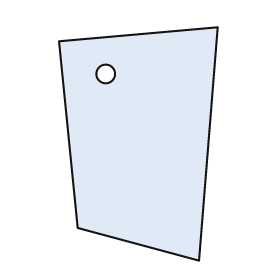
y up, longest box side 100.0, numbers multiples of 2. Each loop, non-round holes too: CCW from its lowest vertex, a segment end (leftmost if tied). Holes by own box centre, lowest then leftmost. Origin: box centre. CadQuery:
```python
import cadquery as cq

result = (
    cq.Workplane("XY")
    .moveTo(26.0, -50.0)
    .lineTo(34.0, 50.0)
    .lineTo(-34.0, 44.0)
    .lineTo(-26.0, -36.0)
    .close()
    .moveTo(-14.0, 30.0)
    .circle(4.0)
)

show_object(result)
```